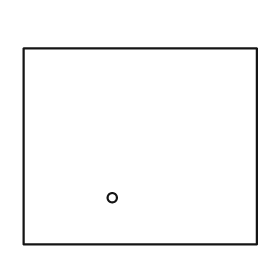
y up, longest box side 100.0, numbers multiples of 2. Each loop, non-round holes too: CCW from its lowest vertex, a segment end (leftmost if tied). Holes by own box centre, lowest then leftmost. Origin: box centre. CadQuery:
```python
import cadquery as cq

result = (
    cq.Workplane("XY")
    .moveTo(-50.0, -42.0)
    .lineTo(50.0, -42.0)
    .lineTo(50.0, 42.0)
    .lineTo(-50.0, 42.0)
    .close()
    .moveTo(-12.0, -22.0)
    .circle(2.0)
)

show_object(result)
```